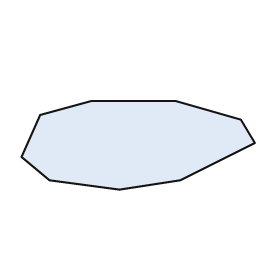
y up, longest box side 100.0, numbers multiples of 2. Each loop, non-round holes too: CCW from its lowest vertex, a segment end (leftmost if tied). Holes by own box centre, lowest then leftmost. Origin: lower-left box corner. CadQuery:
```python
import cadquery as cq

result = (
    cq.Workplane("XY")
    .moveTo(42.0, 0.0)
    .lineTo(68.0, 4.0)
    .lineTo(100.0, 20.0)
    .lineTo(94.0, 30.0)
    .lineTo(66.0, 38.0)
    .lineTo(30.0, 38.0)
    .lineTo(8.0, 32.0)
    .lineTo(0.0, 14.0)
    .lineTo(12.0, 4.0)
    .close()
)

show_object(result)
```